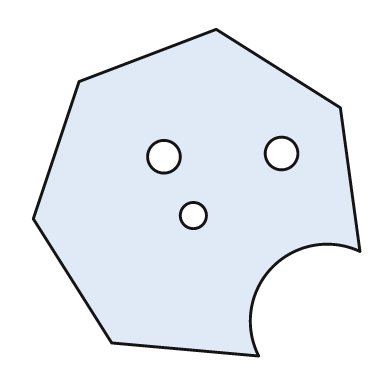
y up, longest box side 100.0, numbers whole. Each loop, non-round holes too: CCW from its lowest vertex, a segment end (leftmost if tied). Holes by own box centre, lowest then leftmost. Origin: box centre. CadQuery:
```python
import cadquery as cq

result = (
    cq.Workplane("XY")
    .moveTo(19.0, -50.0)
    .threePointArc((23.0, -23.0), (50.0, -18.0))
    .lineTo(44.0, 26.0)
    .lineTo(6.0, 50.0)
    .lineTo(-36.0, 34.0)
    .lineTo(-50.0, -8.0)
    .lineTo(-26.0, -46.0)
    .close()
    .moveTo(-1.0, -7.0)
    .circle(4.0)
    .moveTo(-10.0, 11.0)
    .circle(5.0)
    .moveTo(26.0, 12.0)
    .circle(5.0)
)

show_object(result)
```